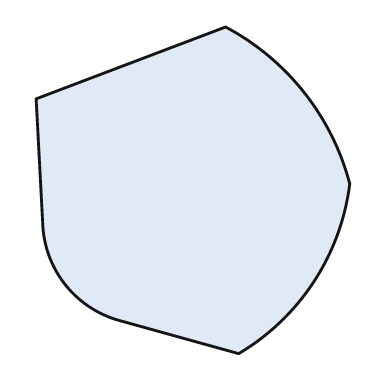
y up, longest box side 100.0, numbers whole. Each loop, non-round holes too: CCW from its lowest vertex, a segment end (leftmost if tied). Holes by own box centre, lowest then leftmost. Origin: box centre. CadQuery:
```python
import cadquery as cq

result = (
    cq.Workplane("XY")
    .moveTo(14.0, -50.0)
    .threePointArc((37.0, -28.0), (48.0, 2.0))
    .threePointArc((34.0, 30.0), (10.0, 50.0))
    .lineTo(-48.0, 28.0)
    .lineTo(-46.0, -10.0)
    .threePointArc((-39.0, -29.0), (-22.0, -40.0))
    .close()
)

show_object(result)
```